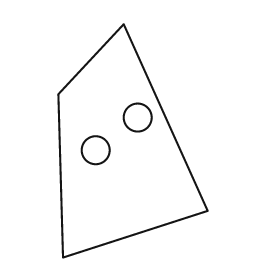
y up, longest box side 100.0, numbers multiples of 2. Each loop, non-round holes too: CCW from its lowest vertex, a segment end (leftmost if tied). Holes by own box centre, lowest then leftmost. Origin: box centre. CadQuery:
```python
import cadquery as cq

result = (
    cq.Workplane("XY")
    .moveTo(-30.0, -50.0)
    .lineTo(32.0, -30.0)
    .lineTo(-4.0, 50.0)
    .lineTo(-32.0, 20.0)
    .close()
    .moveTo(-16.0, -4.0)
    .circle(6.0)
    .moveTo(2.0, 10.0)
    .circle(6.0)
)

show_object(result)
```